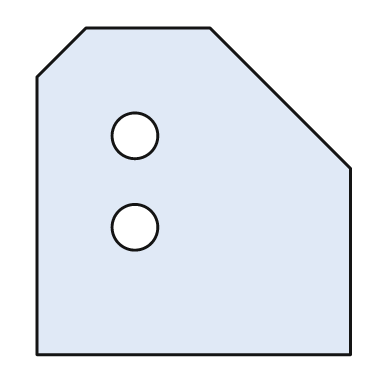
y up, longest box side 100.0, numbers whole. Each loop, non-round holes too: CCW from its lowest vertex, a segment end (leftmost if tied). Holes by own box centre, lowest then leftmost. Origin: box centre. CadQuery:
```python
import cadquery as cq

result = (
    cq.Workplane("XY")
    .moveTo(-48.0, -50.0)
    .lineTo(48.0, -50.0)
    .lineTo(48.0, 7.0)
    .lineTo(5.0, 50.0)
    .lineTo(-33.0, 50.0)
    .lineTo(-48.0, 35.0)
    .close()
    .moveTo(-18.0, -11.0)
    .circle(7.0)
    .moveTo(-18.0, 17.0)
    .circle(7.0)
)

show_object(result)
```